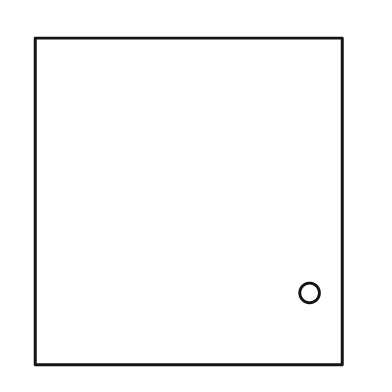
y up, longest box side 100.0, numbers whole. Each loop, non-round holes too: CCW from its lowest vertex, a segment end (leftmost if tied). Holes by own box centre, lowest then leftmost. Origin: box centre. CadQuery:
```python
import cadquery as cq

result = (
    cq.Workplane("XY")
    .moveTo(-47.0, -50.0)
    .lineTo(47.0, -50.0)
    .lineTo(47.0, 50.0)
    .lineTo(-47.0, 50.0)
    .close()
    .moveTo(37.0, -28.0)
    .circle(3.0)
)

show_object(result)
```